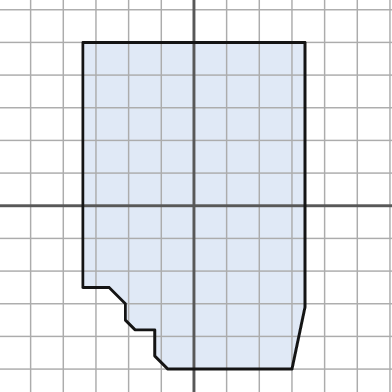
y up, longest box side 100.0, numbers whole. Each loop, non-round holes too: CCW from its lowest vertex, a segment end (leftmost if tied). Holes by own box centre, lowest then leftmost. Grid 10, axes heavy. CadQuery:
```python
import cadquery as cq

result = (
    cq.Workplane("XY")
    .moveTo(-8.0, -50.0)
    .lineTo(30.0, -50.0)
    .lineTo(34.0, -31.0)
    .lineTo(34.0, 50.0)
    .lineTo(-34.0, 50.0)
    .lineTo(-34.0, -25.0)
    .lineTo(-26.0, -25.0)
    .lineTo(-21.0, -30.0)
    .lineTo(-21.0, -35.0)
    .lineTo(-18.0, -38.0)
    .lineTo(-12.0, -38.0)
    .lineTo(-12.0, -46.0)
    .close()
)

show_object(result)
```